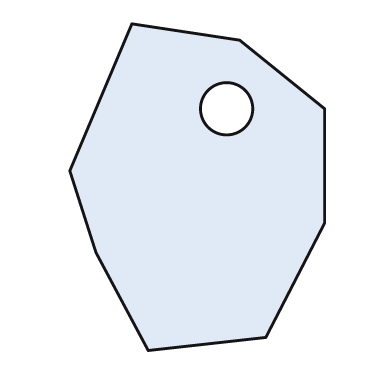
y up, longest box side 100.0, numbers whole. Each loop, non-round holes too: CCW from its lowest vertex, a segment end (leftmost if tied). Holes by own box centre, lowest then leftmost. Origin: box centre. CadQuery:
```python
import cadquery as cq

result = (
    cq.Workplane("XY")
    .moveTo(-15.0, -50.0)
    .lineTo(21.0, -46.0)
    .lineTo(39.0, -11.0)
    .lineTo(39.0, 24.0)
    .lineTo(13.0, 45.0)
    .lineTo(-20.0, 50.0)
    .lineTo(-39.0, 5.0)
    .lineTo(-31.0, -20.0)
    .close()
    .moveTo(9.0, 24.0)
    .circle(8.0)
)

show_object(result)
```